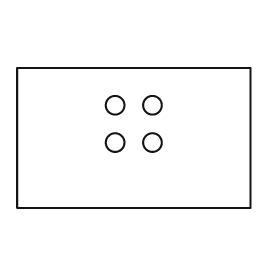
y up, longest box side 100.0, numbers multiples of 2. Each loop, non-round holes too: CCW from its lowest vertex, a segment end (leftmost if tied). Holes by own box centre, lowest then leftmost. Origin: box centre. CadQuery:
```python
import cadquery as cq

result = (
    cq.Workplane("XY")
    .moveTo(-50.0, -30.0)
    .lineTo(50.0, -30.0)
    .lineTo(50.0, 30.0)
    .lineTo(-50.0, 30.0)
    .close()
    .moveTo(-8.0, -2.0)
    .circle(4.0)
    .moveTo(8.0, -2.0)
    .circle(4.0)
    .moveTo(-8.0, 14.0)
    .circle(4.0)
    .moveTo(8.0, 14.0)
    .circle(4.0)
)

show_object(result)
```